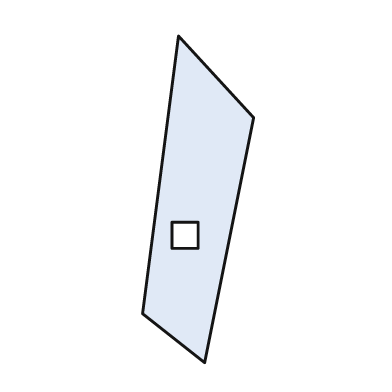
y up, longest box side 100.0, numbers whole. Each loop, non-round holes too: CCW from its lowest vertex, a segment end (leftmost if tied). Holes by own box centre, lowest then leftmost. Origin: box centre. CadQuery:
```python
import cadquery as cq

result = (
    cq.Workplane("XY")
    .moveTo(2.0, -50.0)
    .lineTo(17.0, 25.0)
    .lineTo(-6.0, 50.0)
    .lineTo(-17.0, -35.0)
    .close()
    .moveTo(-8.0, -15.0)
    .lineTo(0.0, -15.0)
    .lineTo(0.0, -7.0)
    .lineTo(-8.0, -7.0)
    .close()
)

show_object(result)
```